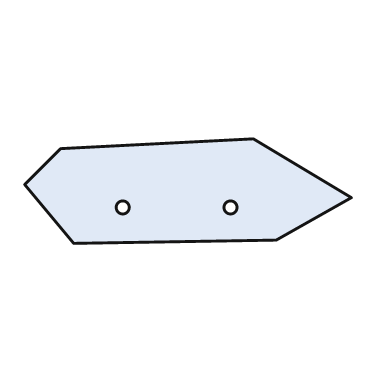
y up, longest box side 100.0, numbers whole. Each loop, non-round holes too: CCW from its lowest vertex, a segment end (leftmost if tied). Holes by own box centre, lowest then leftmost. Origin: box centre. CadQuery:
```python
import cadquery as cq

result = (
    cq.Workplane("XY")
    .moveTo(-35.0, -16.0)
    .lineTo(27.0, -15.0)
    .lineTo(50.0, -2.0)
    .lineTo(20.0, 16.0)
    .lineTo(-39.0, 13.0)
    .lineTo(-50.0, 2.0)
    .close()
    .moveTo(-20.0, -5.0)
    .circle(2.0)
    .moveTo(13.0, -5.0)
    .circle(2.0)
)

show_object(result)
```